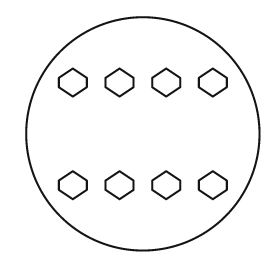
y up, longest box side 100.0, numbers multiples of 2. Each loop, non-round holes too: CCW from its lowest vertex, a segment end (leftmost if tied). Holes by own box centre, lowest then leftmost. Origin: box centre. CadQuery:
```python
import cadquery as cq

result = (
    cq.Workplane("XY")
    .moveTo(0.0, 0.0)
    .circle(50.0)
    .moveTo(-30.0, -28.0)
    .lineTo(-24.0, -24.0)
    .lineTo(-24.0, -20.0)
    .lineTo(-30.0, -16.0)
    .lineTo(-36.0, -20.0)
    .lineTo(-36.0, -24.0)
    .close()
    .moveTo(-10.0, -28.0)
    .lineTo(-4.0, -24.0)
    .lineTo(-4.0, -20.0)
    .lineTo(-10.0, -16.0)
    .lineTo(-16.0, -20.0)
    .lineTo(-16.0, -24.0)
    .close()
    .moveTo(10.0, -28.0)
    .lineTo(16.0, -24.0)
    .lineTo(16.0, -20.0)
    .lineTo(10.0, -16.0)
    .lineTo(4.0, -20.0)
    .lineTo(4.0, -24.0)
    .close()
    .moveTo(30.0, -28.0)
    .lineTo(36.0, -24.0)
    .lineTo(36.0, -20.0)
    .lineTo(30.0, -16.0)
    .lineTo(24.0, -20.0)
    .lineTo(24.0, -24.0)
    .close()
    .moveTo(-30.0, 16.0)
    .lineTo(-24.0, 20.0)
    .lineTo(-24.0, 24.0)
    .lineTo(-30.0, 28.0)
    .lineTo(-36.0, 24.0)
    .lineTo(-36.0, 20.0)
    .close()
    .moveTo(-10.0, 16.0)
    .lineTo(-4.0, 20.0)
    .lineTo(-4.0, 24.0)
    .lineTo(-10.0, 28.0)
    .lineTo(-16.0, 24.0)
    .lineTo(-16.0, 20.0)
    .close()
    .moveTo(10.0, 16.0)
    .lineTo(16.0, 20.0)
    .lineTo(16.0, 24.0)
    .lineTo(10.0, 28.0)
    .lineTo(4.0, 24.0)
    .lineTo(4.0, 20.0)
    .close()
    .moveTo(30.0, 16.0)
    .lineTo(36.0, 20.0)
    .lineTo(36.0, 24.0)
    .lineTo(30.0, 28.0)
    .lineTo(24.0, 24.0)
    .lineTo(24.0, 20.0)
    .close()
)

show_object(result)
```